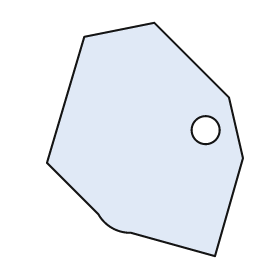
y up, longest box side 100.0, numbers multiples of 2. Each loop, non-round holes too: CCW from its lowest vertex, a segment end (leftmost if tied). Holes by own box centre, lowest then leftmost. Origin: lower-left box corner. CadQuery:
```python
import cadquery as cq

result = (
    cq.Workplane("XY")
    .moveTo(72.0, 0.0)
    .lineTo(84.0, 42.0)
    .lineTo(78.0, 68.0)
    .lineTo(46.0, 100.0)
    .lineTo(16.0, 94.0)
    .lineTo(0.0, 40.0)
    .lineTo(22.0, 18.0)
    .threePointArc((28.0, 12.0), (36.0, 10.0))
    .close()
    .moveTo(68.0, 54.0)
    .circle(6.0)
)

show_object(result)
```